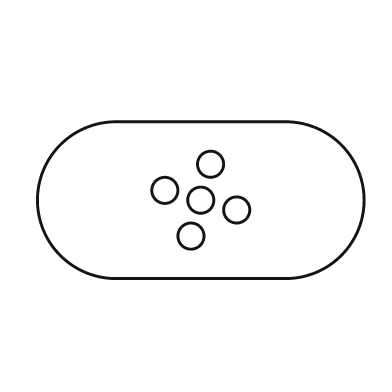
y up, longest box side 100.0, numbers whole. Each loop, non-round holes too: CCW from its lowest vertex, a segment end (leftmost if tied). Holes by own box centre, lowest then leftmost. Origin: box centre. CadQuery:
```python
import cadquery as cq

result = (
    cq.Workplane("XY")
    .moveTo(-26.0, -24.0)
    .lineTo(26.0, -24.0)
    .threePointArc((50.0, 0.0), (26.0, 24.0))
    .lineTo(-26.0, 24.0)
    .threePointArc((-50.0, 0.0), (-26.0, -24.0))
    .close()
    .moveTo(-3.0, -11.0)
    .circle(4.0)
    .moveTo(11.0, -3.0)
    .circle(4.0)
    .moveTo(0.0, 0.0)
    .circle(4.0)
    .moveTo(-11.0, 3.0)
    .circle(4.0)
    .moveTo(3.0, 11.0)
    .circle(4.0)
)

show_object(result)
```